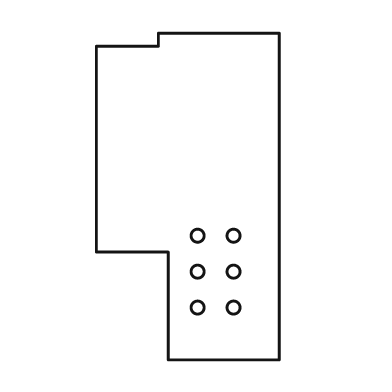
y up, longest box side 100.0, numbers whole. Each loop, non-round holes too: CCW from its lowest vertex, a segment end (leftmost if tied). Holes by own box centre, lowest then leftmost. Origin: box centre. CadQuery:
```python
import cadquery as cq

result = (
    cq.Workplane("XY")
    .moveTo(-6.0, -50.0)
    .lineTo(28.0, -50.0)
    .lineTo(28.0, 50.0)
    .lineTo(-9.0, 50.0)
    .lineTo(-9.0, 46.0)
    .lineTo(-28.0, 46.0)
    .lineTo(-28.0, -17.0)
    .lineTo(-6.0, -17.0)
    .close()
    .moveTo(3.0, -34.0)
    .circle(2.0)
    .moveTo(14.0, -34.0)
    .circle(2.0)
    .moveTo(3.0, -23.0)
    .circle(2.0)
    .moveTo(14.0, -23.0)
    .circle(2.0)
    .moveTo(3.0, -12.0)
    .circle(2.0)
    .moveTo(14.0, -12.0)
    .circle(2.0)
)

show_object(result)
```